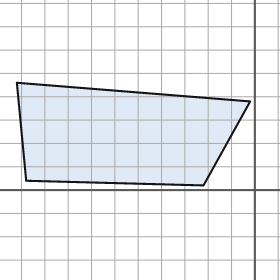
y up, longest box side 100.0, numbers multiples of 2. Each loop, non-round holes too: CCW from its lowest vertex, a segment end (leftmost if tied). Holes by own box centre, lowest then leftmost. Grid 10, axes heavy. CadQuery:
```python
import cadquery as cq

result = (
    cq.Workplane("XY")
    .moveTo(-22.0, 2.0)
    .lineTo(-2.0, 38.0)
    .lineTo(-102.0, 46.0)
    .lineTo(-98.0, 4.0)
    .close()
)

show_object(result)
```